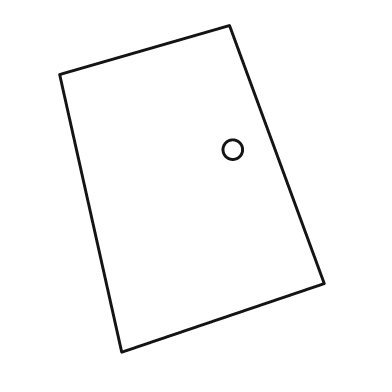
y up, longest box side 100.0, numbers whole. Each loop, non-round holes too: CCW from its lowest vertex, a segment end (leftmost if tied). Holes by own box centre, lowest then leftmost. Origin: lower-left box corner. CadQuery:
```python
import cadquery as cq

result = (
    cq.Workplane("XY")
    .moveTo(19.0, 0.0)
    .lineTo(81.0, 21.0)
    .lineTo(52.0, 100.0)
    .lineTo(0.0, 85.0)
    .close()
    .moveTo(53.0, 62.0)
    .circle(3.0)
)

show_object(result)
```